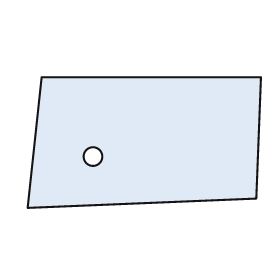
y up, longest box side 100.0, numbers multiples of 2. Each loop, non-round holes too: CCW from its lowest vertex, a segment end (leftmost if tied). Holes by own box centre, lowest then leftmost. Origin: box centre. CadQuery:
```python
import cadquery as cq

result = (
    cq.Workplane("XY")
    .moveTo(-50.0, -28.0)
    .lineTo(48.0, -24.0)
    .lineTo(50.0, 28.0)
    .lineTo(-44.0, 28.0)
    .close()
    .moveTo(-22.0, -6.0)
    .circle(4.0)
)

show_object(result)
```